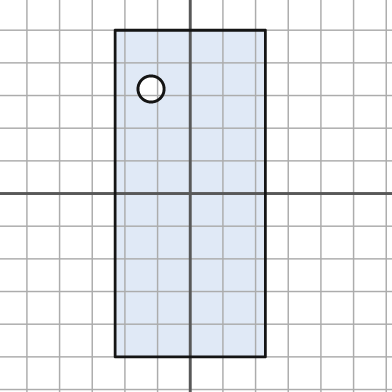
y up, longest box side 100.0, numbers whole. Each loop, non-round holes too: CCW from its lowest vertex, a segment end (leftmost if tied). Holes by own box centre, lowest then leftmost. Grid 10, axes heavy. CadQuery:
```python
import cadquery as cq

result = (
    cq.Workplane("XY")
    .moveTo(-23.0, -50.0)
    .lineTo(23.0, -50.0)
    .lineTo(23.0, 50.0)
    .lineTo(-23.0, 50.0)
    .close()
    .moveTo(-12.0, 32.0)
    .circle(4.0)
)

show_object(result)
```